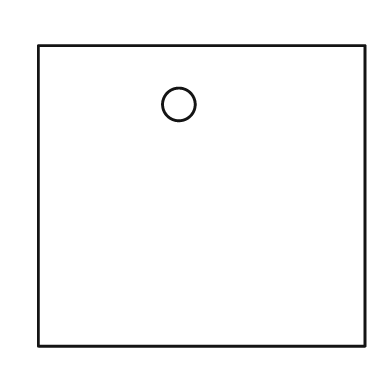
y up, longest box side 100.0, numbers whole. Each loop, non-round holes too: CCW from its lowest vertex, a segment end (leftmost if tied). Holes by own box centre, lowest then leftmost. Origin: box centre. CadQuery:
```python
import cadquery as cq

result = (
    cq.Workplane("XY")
    .moveTo(-50.0, -46.0)
    .lineTo(50.0, -46.0)
    .lineTo(50.0, 46.0)
    .lineTo(-50.0, 46.0)
    .close()
    .moveTo(-7.0, 28.0)
    .circle(5.0)
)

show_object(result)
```